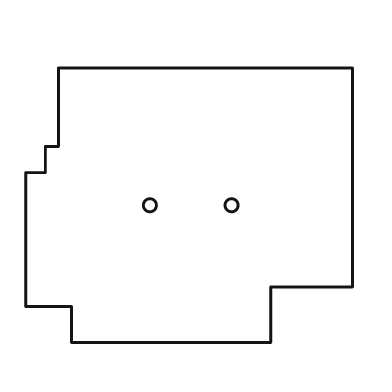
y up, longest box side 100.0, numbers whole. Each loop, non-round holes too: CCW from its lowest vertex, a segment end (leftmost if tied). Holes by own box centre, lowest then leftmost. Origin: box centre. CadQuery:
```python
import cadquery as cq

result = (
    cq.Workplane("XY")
    .moveTo(-36.0, -42.0)
    .lineTo(25.0, -42.0)
    .lineTo(25.0, -25.0)
    .lineTo(50.0, -25.0)
    .lineTo(50.0, 42.0)
    .lineTo(-40.0, 42.0)
    .lineTo(-40.0, 18.0)
    .lineTo(-44.0, 18.0)
    .lineTo(-44.0, 10.0)
    .lineTo(-50.0, 10.0)
    .lineTo(-50.0, -31.0)
    .lineTo(-36.0, -31.0)
    .close()
    .moveTo(-12.0, 0.0)
    .circle(2.0)
    .moveTo(13.0, 0.0)
    .circle(2.0)
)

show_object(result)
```